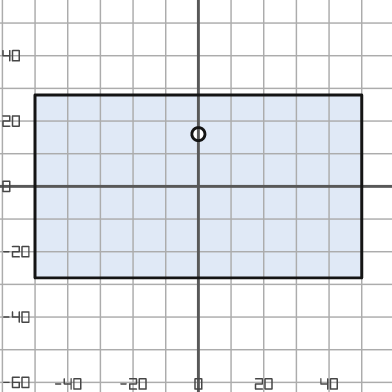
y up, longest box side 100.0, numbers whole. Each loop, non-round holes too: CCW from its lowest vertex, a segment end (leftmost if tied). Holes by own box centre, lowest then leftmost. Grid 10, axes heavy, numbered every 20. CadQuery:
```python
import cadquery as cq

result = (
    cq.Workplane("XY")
    .moveTo(-50.0, -28.0)
    .lineTo(50.0, -28.0)
    .lineTo(50.0, 28.0)
    .lineTo(-50.0, 28.0)
    .close()
    .moveTo(0.0, 16.0)
    .circle(2.0)
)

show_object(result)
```